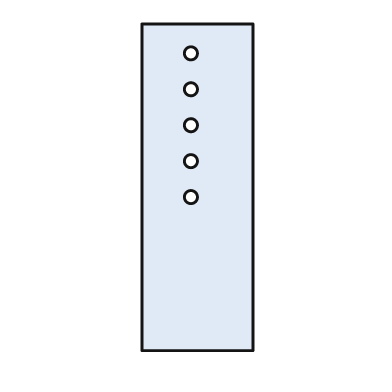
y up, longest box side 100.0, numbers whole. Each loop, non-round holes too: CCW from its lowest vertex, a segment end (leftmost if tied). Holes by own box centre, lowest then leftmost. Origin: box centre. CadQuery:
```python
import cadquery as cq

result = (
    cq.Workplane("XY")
    .moveTo(-17.0, -50.0)
    .lineTo(17.0, -50.0)
    .lineTo(17.0, 50.0)
    .lineTo(-17.0, 50.0)
    .close()
    .moveTo(-2.0, -3.0)
    .circle(2.0)
    .moveTo(-2.0, 8.0)
    .circle(2.0)
    .moveTo(-2.0, 19.0)
    .circle(2.0)
    .moveTo(-2.0, 30.0)
    .circle(2.0)
    .moveTo(-2.0, 41.0)
    .circle(2.0)
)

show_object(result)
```